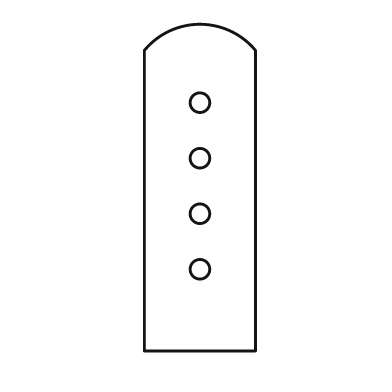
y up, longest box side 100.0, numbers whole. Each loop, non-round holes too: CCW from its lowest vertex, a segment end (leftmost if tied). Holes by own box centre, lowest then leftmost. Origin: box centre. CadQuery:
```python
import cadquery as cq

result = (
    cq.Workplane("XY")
    .moveTo(-17.0, -50.0)
    .lineTo(17.0, -50.0)
    .lineTo(17.0, 42.0)
    .threePointArc((0.0, 50.0), (-17.0, 42.0))
    .close()
    .moveTo(0.0, -25.0)
    .circle(3.0)
    .moveTo(0.0, -8.0)
    .circle(3.0)
    .moveTo(0.0, 9.0)
    .circle(3.0)
    .moveTo(0.0, 26.0)
    .circle(3.0)
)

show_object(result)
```